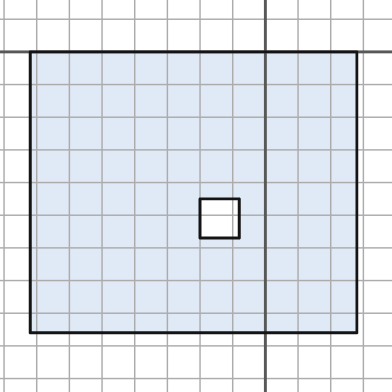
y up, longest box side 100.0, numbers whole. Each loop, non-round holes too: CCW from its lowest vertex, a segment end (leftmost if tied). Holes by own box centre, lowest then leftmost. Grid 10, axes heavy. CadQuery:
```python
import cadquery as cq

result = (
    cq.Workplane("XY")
    .moveTo(-72.0, -86.0)
    .lineTo(28.0, -86.0)
    .lineTo(28.0, 0.0)
    .lineTo(-72.0, 0.0)
    .close()
    .moveTo(-20.0, -57.0)
    .lineTo(-8.0, -57.0)
    .lineTo(-8.0, -45.0)
    .lineTo(-20.0, -45.0)
    .close()
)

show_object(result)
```